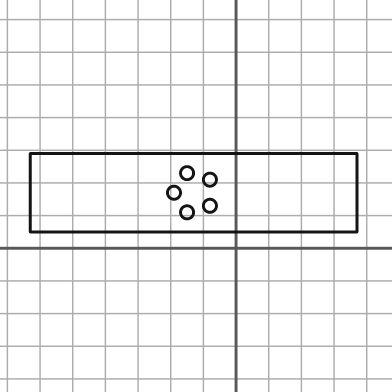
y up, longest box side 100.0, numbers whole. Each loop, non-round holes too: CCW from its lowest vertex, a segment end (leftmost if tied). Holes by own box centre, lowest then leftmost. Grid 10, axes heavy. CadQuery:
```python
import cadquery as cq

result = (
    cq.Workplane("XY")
    .moveTo(-63.0, 5.0)
    .lineTo(37.0, 5.0)
    .lineTo(37.0, 29.0)
    .lineTo(-63.0, 29.0)
    .close()
    .moveTo(-15.0, 11.0)
    .circle(2.0)
    .moveTo(-8.0, 13.0)
    .circle(2.0)
    .moveTo(-19.0, 17.0)
    .circle(2.0)
    .moveTo(-8.0, 21.0)
    .circle(2.0)
    .moveTo(-15.0, 23.0)
    .circle(2.0)
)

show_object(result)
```